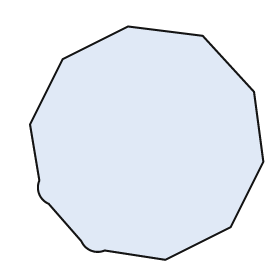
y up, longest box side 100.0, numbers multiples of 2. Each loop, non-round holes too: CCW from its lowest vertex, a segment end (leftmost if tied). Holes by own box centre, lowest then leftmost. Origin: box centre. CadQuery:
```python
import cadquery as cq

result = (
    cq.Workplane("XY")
    .moveTo(8.0, -50.0)
    .lineTo(36.0, -36.0)
    .lineTo(50.0, -8.0)
    .lineTo(46.0, 22.0)
    .lineTo(24.0, 46.0)
    .lineTo(-8.0, 50.0)
    .lineTo(-36.0, 36.0)
    .lineTo(-50.0, 8.0)
    .lineTo(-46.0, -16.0)
    .threePointArc((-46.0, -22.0), (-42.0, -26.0))
    .lineTo(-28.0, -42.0)
    .threePointArc((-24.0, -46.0), (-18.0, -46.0))
    .close()
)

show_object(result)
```